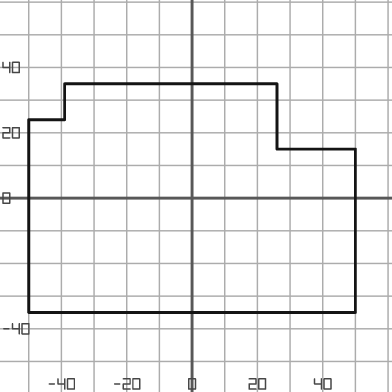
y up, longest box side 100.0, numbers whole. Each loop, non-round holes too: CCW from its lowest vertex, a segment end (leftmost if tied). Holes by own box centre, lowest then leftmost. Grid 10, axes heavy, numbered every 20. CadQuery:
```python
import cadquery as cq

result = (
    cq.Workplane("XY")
    .moveTo(-50.0, -35.0)
    .lineTo(50.0, -35.0)
    .lineTo(50.0, 15.0)
    .lineTo(26.0, 15.0)
    .lineTo(26.0, 35.0)
    .lineTo(-39.0, 35.0)
    .lineTo(-39.0, 24.0)
    .lineTo(-50.0, 24.0)
    .close()
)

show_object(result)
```